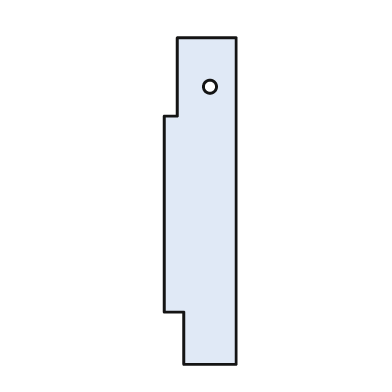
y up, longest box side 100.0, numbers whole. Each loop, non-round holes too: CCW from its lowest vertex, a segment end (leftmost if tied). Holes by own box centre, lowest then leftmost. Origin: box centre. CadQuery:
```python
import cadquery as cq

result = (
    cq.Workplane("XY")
    .moveTo(-5.0, -50.0)
    .lineTo(11.0, -50.0)
    .lineTo(11.0, 50.0)
    .lineTo(-7.0, 50.0)
    .lineTo(-7.0, 26.0)
    .lineTo(-11.0, 26.0)
    .lineTo(-11.0, -34.0)
    .lineTo(-5.0, -34.0)
    .close()
    .moveTo(3.0, 35.0)
    .circle(2.0)
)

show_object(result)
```